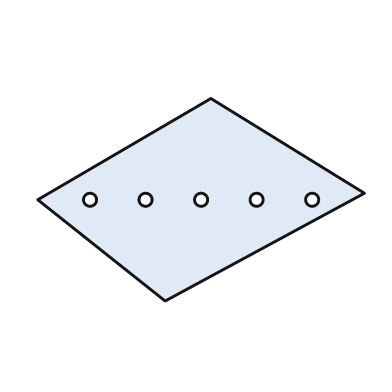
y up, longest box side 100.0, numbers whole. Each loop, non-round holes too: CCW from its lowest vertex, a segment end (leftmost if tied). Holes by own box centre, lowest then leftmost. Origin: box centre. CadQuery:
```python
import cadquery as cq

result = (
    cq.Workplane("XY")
    .moveTo(-11.0, -31.0)
    .lineTo(50.0, 2.0)
    .lineTo(3.0, 31.0)
    .lineTo(-50.0, 0.0)
    .close()
    .moveTo(-34.0, 0.0)
    .circle(2.0)
    .moveTo(-17.0, 0.0)
    .circle(2.0)
    .moveTo(0.0, 0.0)
    .circle(2.0)
    .moveTo(17.0, 0.0)
    .circle(2.0)
    .moveTo(34.0, 0.0)
    .circle(2.0)
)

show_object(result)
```